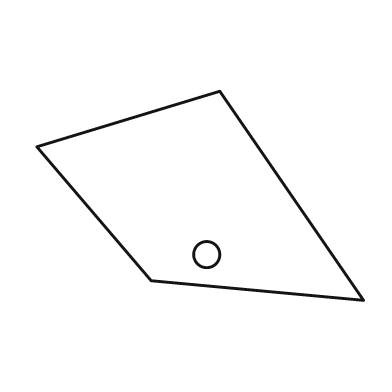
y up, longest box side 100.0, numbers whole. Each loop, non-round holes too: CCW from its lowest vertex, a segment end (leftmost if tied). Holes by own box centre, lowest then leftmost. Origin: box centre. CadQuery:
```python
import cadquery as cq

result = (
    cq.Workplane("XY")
    .moveTo(50.0, -32.0)
    .lineTo(6.0, 32.0)
    .lineTo(-50.0, 15.0)
    .lineTo(-15.0, -26.0)
    .close()
    .moveTo(2.0, -18.0)
    .circle(4.0)
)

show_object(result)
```